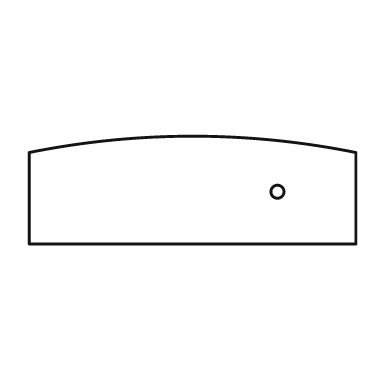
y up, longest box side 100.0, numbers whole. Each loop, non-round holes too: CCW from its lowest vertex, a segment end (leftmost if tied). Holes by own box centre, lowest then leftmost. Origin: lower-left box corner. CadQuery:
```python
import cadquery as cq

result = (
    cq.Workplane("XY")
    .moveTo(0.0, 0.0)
    .lineTo(100.0, 0.0)
    .lineTo(100.0, 28.0)
    .threePointArc((50.0, 33.0), (0.0, 28.0))
    .close()
    .moveTo(76.0, 16.0)
    .circle(2.0)
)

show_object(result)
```